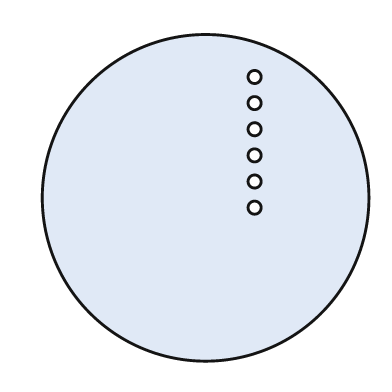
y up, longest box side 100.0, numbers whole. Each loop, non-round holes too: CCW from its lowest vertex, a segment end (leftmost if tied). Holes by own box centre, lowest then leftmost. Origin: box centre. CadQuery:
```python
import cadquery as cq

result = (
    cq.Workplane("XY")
    .moveTo(0.0, 0.0)
    .circle(50.0)
    .moveTo(15.0, -3.0)
    .circle(2.0)
    .moveTo(15.0, 5.0)
    .circle(2.0)
    .moveTo(15.0, 13.0)
    .circle(2.0)
    .moveTo(15.0, 21.0)
    .circle(2.0)
    .moveTo(15.0, 29.0)
    .circle(2.0)
    .moveTo(15.0, 37.0)
    .circle(2.0)
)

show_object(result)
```